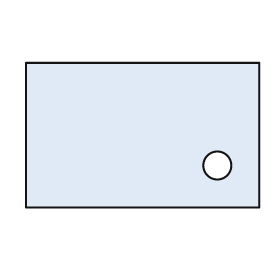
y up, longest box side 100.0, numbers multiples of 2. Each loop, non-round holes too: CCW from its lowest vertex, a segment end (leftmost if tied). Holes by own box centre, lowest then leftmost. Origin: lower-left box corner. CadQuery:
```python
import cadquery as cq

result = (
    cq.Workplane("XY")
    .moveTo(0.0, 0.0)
    .lineTo(100.0, 0.0)
    .lineTo(100.0, 62.0)
    .lineTo(0.0, 62.0)
    .close()
    .moveTo(82.0, 18.0)
    .circle(6.0)
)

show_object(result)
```